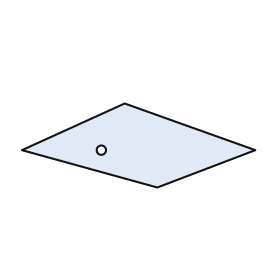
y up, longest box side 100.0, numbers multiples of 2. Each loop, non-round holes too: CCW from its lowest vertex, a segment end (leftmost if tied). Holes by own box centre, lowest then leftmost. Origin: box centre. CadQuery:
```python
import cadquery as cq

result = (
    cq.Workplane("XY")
    .moveTo(8.0, -18.0)
    .lineTo(50.0, -2.0)
    .lineTo(-6.0, 18.0)
    .lineTo(-50.0, -2.0)
    .close()
    .moveTo(-16.0, -2.0)
    .circle(2.0)
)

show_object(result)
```